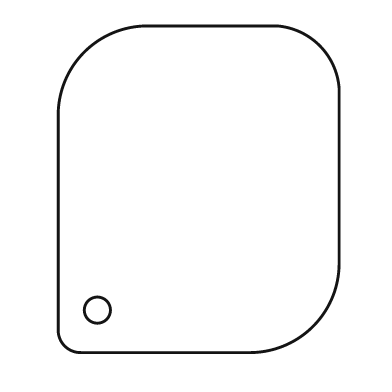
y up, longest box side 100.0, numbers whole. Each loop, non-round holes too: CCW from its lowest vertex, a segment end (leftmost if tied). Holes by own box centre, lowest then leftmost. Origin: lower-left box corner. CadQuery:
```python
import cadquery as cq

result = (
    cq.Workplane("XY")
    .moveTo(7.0, 0.0)
    .lineTo(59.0, 0.0)
    .threePointArc((78.0, 8.0), (86.0, 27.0))
    .lineTo(86.0, 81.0)
    .threePointArc((80.0, 94.0), (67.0, 100.0))
    .lineTo(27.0, 100.0)
    .threePointArc((8.0, 92.0), (0.0, 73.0))
    .lineTo(0.0, 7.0)
    .threePointArc((2.0, 2.0), (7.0, 0.0))
    .close()
    .moveTo(12.0, 13.0)
    .circle(4.0)
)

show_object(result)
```